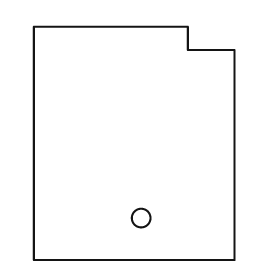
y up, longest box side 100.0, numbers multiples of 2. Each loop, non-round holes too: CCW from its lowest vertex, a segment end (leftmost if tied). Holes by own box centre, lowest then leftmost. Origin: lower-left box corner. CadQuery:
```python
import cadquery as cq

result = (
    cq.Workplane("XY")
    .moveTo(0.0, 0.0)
    .lineTo(86.0, 0.0)
    .lineTo(86.0, 90.0)
    .lineTo(66.0, 90.0)
    .lineTo(66.0, 100.0)
    .lineTo(0.0, 100.0)
    .close()
    .moveTo(46.0, 18.0)
    .circle(4.0)
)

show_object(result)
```